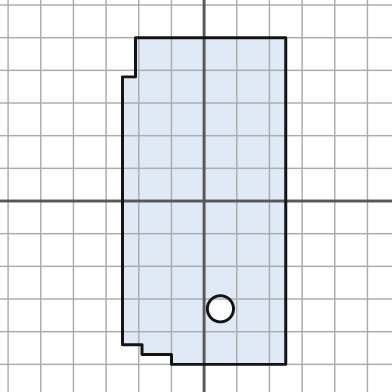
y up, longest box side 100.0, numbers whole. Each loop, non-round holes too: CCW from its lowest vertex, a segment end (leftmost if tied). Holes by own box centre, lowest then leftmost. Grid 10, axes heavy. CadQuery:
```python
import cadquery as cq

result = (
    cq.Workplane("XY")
    .moveTo(-10.0, -50.0)
    .lineTo(25.0, -50.0)
    .lineTo(25.0, 50.0)
    .lineTo(-21.0, 50.0)
    .lineTo(-21.0, 38.0)
    .lineTo(-25.0, 38.0)
    .lineTo(-25.0, -44.0)
    .lineTo(-19.0, -44.0)
    .lineTo(-19.0, -47.0)
    .lineTo(-10.0, -47.0)
    .close()
    .moveTo(5.0, -33.0)
    .circle(4.0)
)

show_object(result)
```